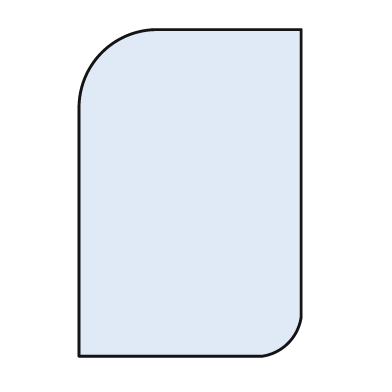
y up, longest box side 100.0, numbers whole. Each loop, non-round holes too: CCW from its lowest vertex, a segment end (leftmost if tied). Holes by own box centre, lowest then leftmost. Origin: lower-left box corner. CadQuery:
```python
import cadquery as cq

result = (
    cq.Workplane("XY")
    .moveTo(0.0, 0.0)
    .lineTo(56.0, 0.0)
    .threePointArc((64.0, 4.0), (68.0, 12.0))
    .lineTo(68.0, 100.0)
    .lineTo(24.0, 100.0)
    .threePointArc((7.0, 93.0), (0.0, 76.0))
    .close()
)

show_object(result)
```